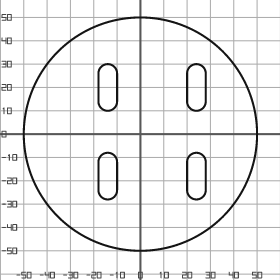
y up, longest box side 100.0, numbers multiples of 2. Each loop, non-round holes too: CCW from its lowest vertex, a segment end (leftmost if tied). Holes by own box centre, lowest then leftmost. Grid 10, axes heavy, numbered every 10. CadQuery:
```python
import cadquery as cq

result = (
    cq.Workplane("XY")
    .moveTo(0.0, 0.0)
    .circle(50.0)
    .moveTo(-18.0, -24.0)
    .threePointArc((-14.0, -28.0), (-10.0, -24.0))
    .lineTo(-10.0, -12.0)
    .threePointArc((-14.0, -8.0), (-18.0, -12.0))
    .close()
    .moveTo(20.0, -24.0)
    .threePointArc((24.0, -28.0), (28.0, -24.0))
    .lineTo(28.0, -12.0)
    .threePointArc((24.0, -8.0), (20.0, -12.0))
    .close()
    .moveTo(-18.0, 14.0)
    .threePointArc((-14.0, 10.0), (-10.0, 14.0))
    .lineTo(-10.0, 26.0)
    .threePointArc((-14.0, 30.0), (-18.0, 26.0))
    .close()
    .moveTo(20.0, 14.0)
    .threePointArc((24.0, 10.0), (28.0, 14.0))
    .lineTo(28.0, 26.0)
    .threePointArc((24.0, 30.0), (20.0, 26.0))
    .close()
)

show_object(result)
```